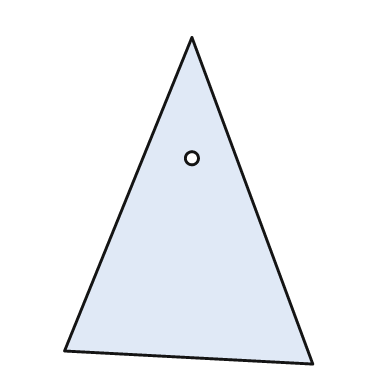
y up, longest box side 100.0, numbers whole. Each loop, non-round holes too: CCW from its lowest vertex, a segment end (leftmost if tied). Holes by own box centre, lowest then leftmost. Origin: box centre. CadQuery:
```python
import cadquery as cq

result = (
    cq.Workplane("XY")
    .moveTo(38.0, -50.0)
    .lineTo(1.0, 50.0)
    .lineTo(-38.0, -46.0)
    .close()
    .moveTo(1.0, 13.0)
    .circle(2.0)
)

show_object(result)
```